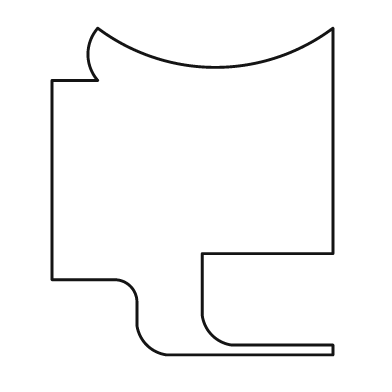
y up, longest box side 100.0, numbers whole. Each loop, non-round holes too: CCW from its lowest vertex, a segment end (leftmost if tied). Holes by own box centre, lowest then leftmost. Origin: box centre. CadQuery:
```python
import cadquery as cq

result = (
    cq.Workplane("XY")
    .moveTo(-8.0, -50.0)
    .lineTo(43.0, -50.0)
    .lineTo(43.0, -47.0)
    .lineTo(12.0, -47.0)
    .threePointArc((6.0, -44.0), (3.0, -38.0))
    .lineTo(3.0, -19.0)
    .lineTo(43.0, -19.0)
    .lineTo(43.0, 50.0)
    .threePointArc((7.0, 38.0), (-29.0, 50.0))
    .threePointArc((-32.0, 42.0), (-29.0, 34.0))
    .lineTo(-43.0, 34.0)
    .lineTo(-43.0, -27.0)
    .lineTo(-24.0, -27.0)
    .threePointArc((-19.0, -29.0), (-17.0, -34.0))
    .lineTo(-17.0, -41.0)
    .threePointArc((-14.0, -47.0), (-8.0, -50.0))
    .close()
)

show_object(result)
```